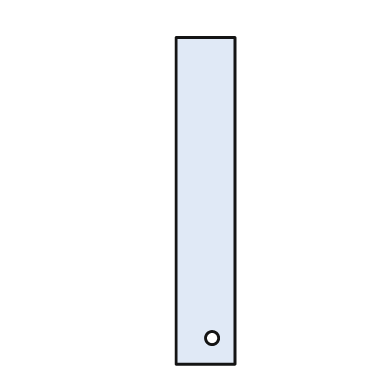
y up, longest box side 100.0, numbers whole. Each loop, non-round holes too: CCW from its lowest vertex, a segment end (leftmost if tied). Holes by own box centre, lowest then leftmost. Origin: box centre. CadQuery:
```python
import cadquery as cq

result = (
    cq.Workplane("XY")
    .moveTo(-9.0, -50.0)
    .lineTo(9.0, -50.0)
    .lineTo(9.0, 50.0)
    .lineTo(-9.0, 50.0)
    .close()
    .moveTo(2.0, -42.0)
    .circle(2.0)
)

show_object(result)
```